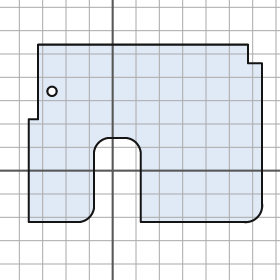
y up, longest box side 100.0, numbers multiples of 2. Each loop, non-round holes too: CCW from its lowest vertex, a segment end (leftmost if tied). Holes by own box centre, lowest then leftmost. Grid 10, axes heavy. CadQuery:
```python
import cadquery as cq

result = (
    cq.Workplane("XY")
    .moveTo(-36.0, -22.0)
    .lineTo(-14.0, -22.0)
    .threePointArc((-10.0, -20.0), (-8.0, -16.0))
    .lineTo(-8.0, 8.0)
    .threePointArc((-6.0, 12.0), (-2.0, 14.0))
    .lineTo(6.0, 14.0)
    .threePointArc((10.0, 12.0), (12.0, 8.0))
    .lineTo(12.0, -22.0)
    .lineTo(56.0, -22.0)
    .threePointArc((62.0, -20.0), (64.0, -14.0))
    .lineTo(64.0, 46.0)
    .lineTo(58.0, 46.0)
    .lineTo(58.0, 54.0)
    .lineTo(-32.0, 54.0)
    .lineTo(-32.0, 22.0)
    .lineTo(-36.0, 22.0)
    .close()
    .moveTo(-26.0, 34.0)
    .circle(2.0)
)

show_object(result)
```